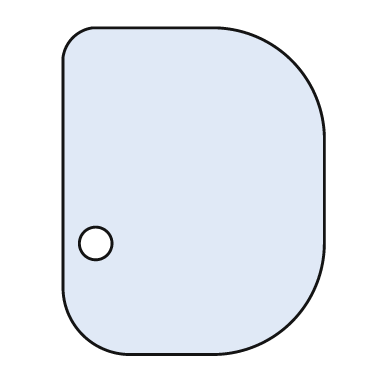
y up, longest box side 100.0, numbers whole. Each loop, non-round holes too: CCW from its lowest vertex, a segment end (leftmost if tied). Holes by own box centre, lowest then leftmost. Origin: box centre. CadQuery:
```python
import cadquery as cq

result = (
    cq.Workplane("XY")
    .moveTo(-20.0, -50.0)
    .lineTo(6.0, -50.0)
    .threePointArc((30.0, -40.0), (40.0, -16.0))
    .lineTo(40.0, 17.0)
    .threePointArc((30.0, 40.0), (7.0, 50.0))
    .lineTo(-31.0, 50.0)
    .threePointArc((-37.0, 47.0), (-40.0, 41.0))
    .lineTo(-40.0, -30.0)
    .threePointArc((-34.0, -44.0), (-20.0, -50.0))
    .close()
    .moveTo(-30.0, -16.0)
    .circle(5.0)
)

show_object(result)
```